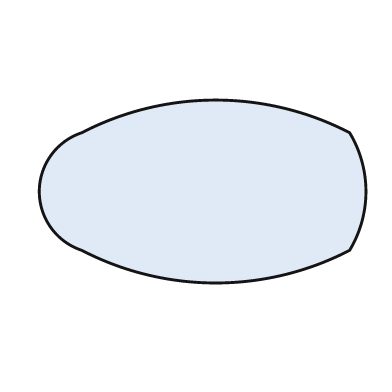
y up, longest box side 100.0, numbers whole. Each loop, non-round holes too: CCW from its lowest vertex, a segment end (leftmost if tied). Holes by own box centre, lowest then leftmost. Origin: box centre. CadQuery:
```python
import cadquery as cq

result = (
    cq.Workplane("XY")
    .moveTo(-37.0, -18.0)
    .threePointArc((4.0, -28.0), (45.0, -18.0))
    .threePointArc((50.0, 0.0), (45.0, 18.0))
    .threePointArc((4.0, 28.0), (-37.0, 18.0))
    .threePointArc((-50.0, 0.0), (-37.0, -18.0))
    .close()
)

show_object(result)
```